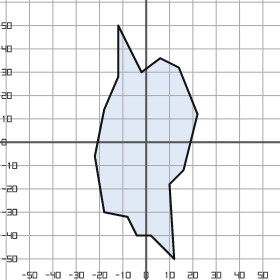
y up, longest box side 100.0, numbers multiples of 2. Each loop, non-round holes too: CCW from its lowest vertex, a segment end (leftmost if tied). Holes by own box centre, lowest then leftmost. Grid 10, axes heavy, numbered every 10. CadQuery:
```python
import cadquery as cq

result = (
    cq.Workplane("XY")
    .moveTo(12.0, -50.0)
    .lineTo(10.0, -18.0)
    .lineTo(16.0, -12.0)
    .lineTo(22.0, 12.0)
    .lineTo(14.0, 32.0)
    .lineTo(6.0, 36.0)
    .lineTo(-2.0, 30.0)
    .lineTo(-12.0, 50.0)
    .lineTo(-12.0, 28.0)
    .lineTo(-18.0, 14.0)
    .lineTo(-22.0, -6.0)
    .lineTo(-18.0, -30.0)
    .lineTo(-8.0, -32.0)
    .lineTo(-4.0, -40.0)
    .lineTo(2.0, -40.0)
    .close()
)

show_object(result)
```